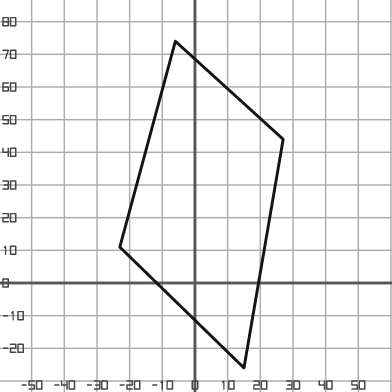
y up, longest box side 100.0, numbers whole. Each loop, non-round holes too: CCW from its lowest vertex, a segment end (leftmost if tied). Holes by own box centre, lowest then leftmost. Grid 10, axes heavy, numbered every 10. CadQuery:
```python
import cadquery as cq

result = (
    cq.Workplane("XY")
    .moveTo(15.0, -26.0)
    .lineTo(27.0, 44.0)
    .lineTo(-6.0, 74.0)
    .lineTo(-23.0, 11.0)
    .close()
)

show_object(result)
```